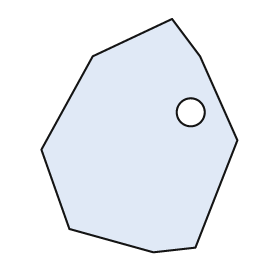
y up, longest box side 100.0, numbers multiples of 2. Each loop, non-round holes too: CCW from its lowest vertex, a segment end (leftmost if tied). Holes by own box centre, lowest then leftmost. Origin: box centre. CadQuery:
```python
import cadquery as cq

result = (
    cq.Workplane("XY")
    .moveTo(6.0, -50.0)
    .lineTo(24.0, -48.0)
    .lineTo(42.0, -2.0)
    .lineTo(26.0, 34.0)
    .lineTo(14.0, 50.0)
    .lineTo(-20.0, 34.0)
    .lineTo(-42.0, -6.0)
    .lineTo(-30.0, -40.0)
    .close()
    .moveTo(22.0, 10.0)
    .circle(6.0)
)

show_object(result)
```